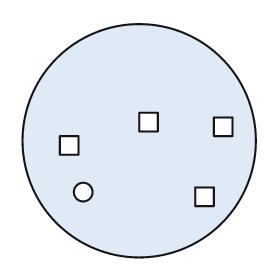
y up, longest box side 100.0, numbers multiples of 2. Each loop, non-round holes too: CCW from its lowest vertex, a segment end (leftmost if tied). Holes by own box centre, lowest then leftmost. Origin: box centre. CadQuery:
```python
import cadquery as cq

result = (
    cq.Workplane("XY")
    .moveTo(0.0, 0.0)
    .circle(50.0)
    .moveTo(24.0, -28.0)
    .lineTo(32.0, -28.0)
    .lineTo(32.0, -20.0)
    .lineTo(24.0, -20.0)
    .close()
    .moveTo(-24.0, -22.0)
    .circle(4.0)
    .moveTo(-34.0, -6.0)
    .lineTo(-26.0, -6.0)
    .lineTo(-26.0, 2.0)
    .lineTo(-34.0, 2.0)
    .close()
    .moveTo(32.0, 2.0)
    .lineTo(40.0, 2.0)
    .lineTo(40.0, 10.0)
    .lineTo(32.0, 10.0)
    .close()
    .moveTo(0.0, 4.0)
    .lineTo(8.0, 4.0)
    .lineTo(8.0, 12.0)
    .lineTo(0.0, 12.0)
    .close()
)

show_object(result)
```